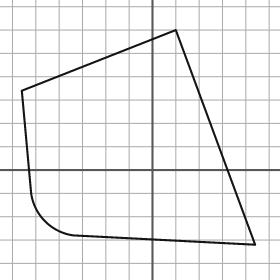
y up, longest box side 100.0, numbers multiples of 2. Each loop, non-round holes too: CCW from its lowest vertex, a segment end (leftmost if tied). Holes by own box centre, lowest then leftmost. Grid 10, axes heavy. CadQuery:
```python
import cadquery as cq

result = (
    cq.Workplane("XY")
    .moveTo(44.0, -32.0)
    .lineTo(10.0, 60.0)
    .lineTo(-56.0, 34.0)
    .lineTo(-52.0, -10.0)
    .threePointArc((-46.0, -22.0), (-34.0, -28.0))
    .close()
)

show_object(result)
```